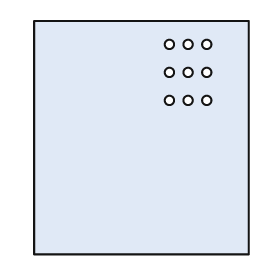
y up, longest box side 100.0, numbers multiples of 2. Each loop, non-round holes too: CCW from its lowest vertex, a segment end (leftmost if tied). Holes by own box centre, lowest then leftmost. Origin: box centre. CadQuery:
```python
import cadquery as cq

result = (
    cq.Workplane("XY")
    .moveTo(-46.0, -50.0)
    .lineTo(46.0, -50.0)
    .lineTo(46.0, 50.0)
    .lineTo(-46.0, 50.0)
    .close()
    .moveTo(12.0, 16.0)
    .circle(2.0)
    .moveTo(20.0, 16.0)
    .circle(2.0)
    .moveTo(28.0, 16.0)
    .circle(2.0)
    .moveTo(12.0, 28.0)
    .circle(2.0)
    .moveTo(20.0, 28.0)
    .circle(2.0)
    .moveTo(28.0, 28.0)
    .circle(2.0)
    .moveTo(12.0, 40.0)
    .circle(2.0)
    .moveTo(20.0, 40.0)
    .circle(2.0)
    .moveTo(28.0, 40.0)
    .circle(2.0)
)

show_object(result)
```